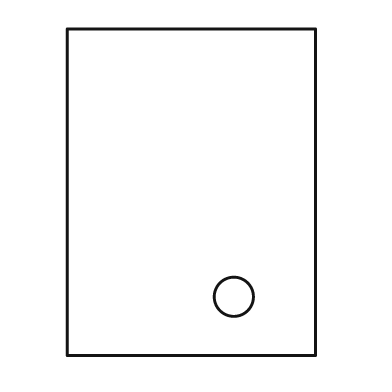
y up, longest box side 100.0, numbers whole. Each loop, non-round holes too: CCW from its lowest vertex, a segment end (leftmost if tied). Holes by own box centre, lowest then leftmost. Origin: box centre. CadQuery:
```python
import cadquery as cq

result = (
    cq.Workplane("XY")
    .moveTo(-38.0, -50.0)
    .lineTo(38.0, -50.0)
    .lineTo(38.0, 50.0)
    .lineTo(-38.0, 50.0)
    .close()
    .moveTo(13.0, -32.0)
    .circle(6.0)
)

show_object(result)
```